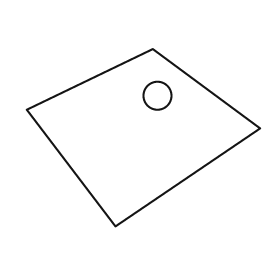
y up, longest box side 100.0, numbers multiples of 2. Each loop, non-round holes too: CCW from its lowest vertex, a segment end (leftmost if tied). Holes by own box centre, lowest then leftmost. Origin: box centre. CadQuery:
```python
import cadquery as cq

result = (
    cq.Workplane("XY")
    .moveTo(-12.0, -38.0)
    .lineTo(50.0, 4.0)
    .lineTo(4.0, 38.0)
    .lineTo(-50.0, 12.0)
    .close()
    .moveTo(6.0, 18.0)
    .circle(6.0)
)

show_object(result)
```